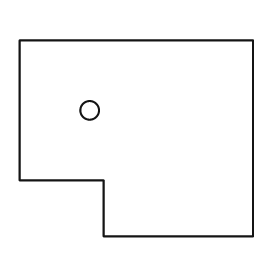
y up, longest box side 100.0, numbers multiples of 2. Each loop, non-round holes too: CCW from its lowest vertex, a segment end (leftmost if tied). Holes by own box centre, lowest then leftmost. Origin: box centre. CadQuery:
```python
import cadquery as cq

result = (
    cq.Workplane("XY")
    .moveTo(-14.0, -42.0)
    .lineTo(50.0, -42.0)
    .lineTo(50.0, 42.0)
    .lineTo(-50.0, 42.0)
    .lineTo(-50.0, -18.0)
    .lineTo(-14.0, -18.0)
    .close()
    .moveTo(-20.0, 12.0)
    .circle(4.0)
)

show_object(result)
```